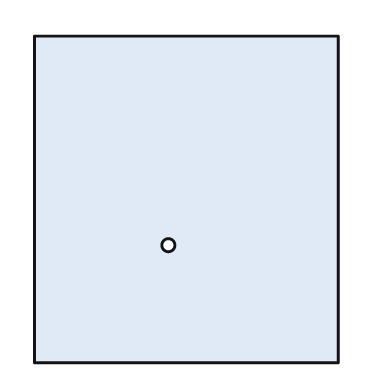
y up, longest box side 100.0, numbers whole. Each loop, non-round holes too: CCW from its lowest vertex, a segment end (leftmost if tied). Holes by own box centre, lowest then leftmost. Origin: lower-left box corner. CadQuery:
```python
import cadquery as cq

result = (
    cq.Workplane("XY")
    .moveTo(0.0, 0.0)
    .lineTo(93.0, 0.0)
    .lineTo(93.0, 100.0)
    .lineTo(0.0, 100.0)
    .close()
    .moveTo(41.0, 36.0)
    .circle(2.0)
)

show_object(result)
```